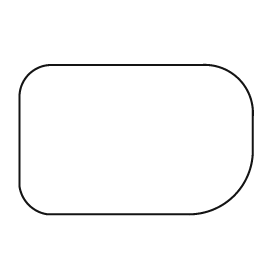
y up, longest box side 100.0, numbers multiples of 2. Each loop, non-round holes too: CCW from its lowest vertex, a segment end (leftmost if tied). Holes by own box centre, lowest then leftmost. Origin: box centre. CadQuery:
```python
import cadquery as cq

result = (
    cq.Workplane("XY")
    .moveTo(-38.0, -32.0)
    .lineTo(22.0, -32.0)
    .threePointArc((42.0, -24.0), (50.0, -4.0))
    .lineTo(50.0, 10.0)
    .threePointArc((44.0, 26.0), (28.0, 32.0))
    .lineTo(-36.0, 32.0)
    .threePointArc((-46.0, 28.0), (-50.0, 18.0))
    .lineTo(-50.0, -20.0)
    .threePointArc((-46.0, -28.0), (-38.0, -32.0))
    .close()
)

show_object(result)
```